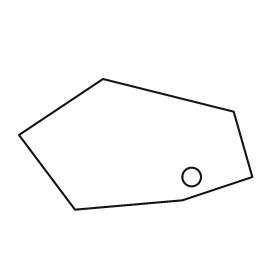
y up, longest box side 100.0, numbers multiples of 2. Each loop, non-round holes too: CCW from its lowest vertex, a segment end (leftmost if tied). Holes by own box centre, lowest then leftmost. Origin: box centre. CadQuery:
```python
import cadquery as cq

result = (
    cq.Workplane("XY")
    .moveTo(-26.0, -28.0)
    .lineTo(20.0, -24.0)
    .lineTo(50.0, -14.0)
    .lineTo(42.0, 14.0)
    .lineTo(-14.0, 28.0)
    .lineTo(-50.0, 4.0)
    .close()
    .moveTo(24.0, -14.0)
    .circle(4.0)
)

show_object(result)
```